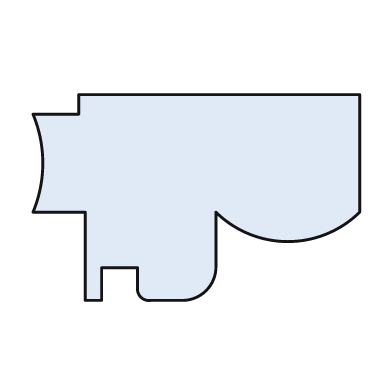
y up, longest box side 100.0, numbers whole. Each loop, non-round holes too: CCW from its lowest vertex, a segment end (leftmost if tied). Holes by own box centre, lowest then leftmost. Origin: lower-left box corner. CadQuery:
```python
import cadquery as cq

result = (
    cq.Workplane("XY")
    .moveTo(16.0, 0.0)
    .lineTo(21.0, 0.0)
    .lineTo(21.0, 10.0)
    .lineTo(32.0, 10.0)
    .lineTo(32.0, 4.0)
    .threePointArc((33.0, 1.0), (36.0, 0.0))
    .lineTo(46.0, 0.0)
    .threePointArc((53.0, 3.0), (56.0, 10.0))
    .lineTo(56.0, 27.0)
    .threePointArc((78.0, 18.0), (100.0, 27.0))
    .lineTo(100.0, 63.0)
    .lineTo(14.0, 63.0)
    .lineTo(14.0, 57.0)
    .lineTo(0.0, 57.0)
    .threePointArc((3.0, 42.0), (0.0, 27.0))
    .lineTo(16.0, 27.0)
    .close()
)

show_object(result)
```